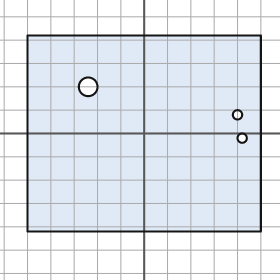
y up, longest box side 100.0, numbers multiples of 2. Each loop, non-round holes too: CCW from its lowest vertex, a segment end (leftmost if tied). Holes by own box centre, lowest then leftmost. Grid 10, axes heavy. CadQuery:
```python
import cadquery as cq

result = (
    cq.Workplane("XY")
    .moveTo(-50.0, -42.0)
    .lineTo(50.0, -42.0)
    .lineTo(50.0, 42.0)
    .lineTo(-50.0, 42.0)
    .close()
    .moveTo(42.0, -2.0)
    .circle(2.0)
    .moveTo(40.0, 8.0)
    .circle(2.0)
    .moveTo(-24.0, 20.0)
    .circle(4.0)
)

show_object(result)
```